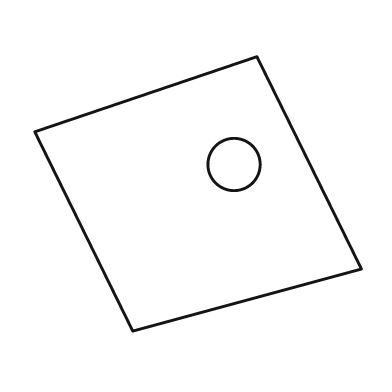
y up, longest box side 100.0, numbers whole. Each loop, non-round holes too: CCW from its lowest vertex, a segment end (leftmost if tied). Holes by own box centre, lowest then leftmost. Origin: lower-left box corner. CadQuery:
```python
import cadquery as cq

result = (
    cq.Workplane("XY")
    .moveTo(30.0, 0.0)
    .lineTo(100.0, 19.0)
    .lineTo(68.0, 84.0)
    .lineTo(0.0, 61.0)
    .close()
    .moveTo(61.0, 51.0)
    .circle(8.0)
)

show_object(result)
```